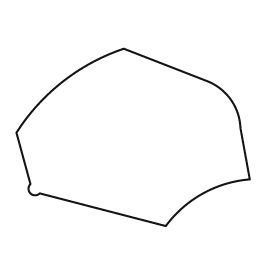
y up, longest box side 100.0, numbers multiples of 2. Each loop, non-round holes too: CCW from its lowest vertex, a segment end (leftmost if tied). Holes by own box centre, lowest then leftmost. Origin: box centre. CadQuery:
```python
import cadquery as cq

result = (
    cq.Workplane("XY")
    .moveTo(14.0, -38.0)
    .threePointArc((30.0, -24.0), (50.0, -18.0))
    .lineTo(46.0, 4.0)
    .threePointArc((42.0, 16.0), (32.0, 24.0))
    .lineTo(-4.0, 38.0)
    .threePointArc((-30.0, 24.0), (-50.0, 2.0))
    .lineTo(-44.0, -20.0)
    .threePointArc((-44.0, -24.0), (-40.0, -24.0))
    .close()
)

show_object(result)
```